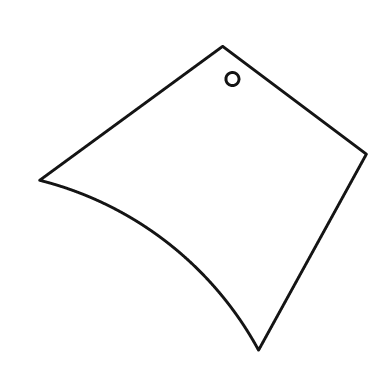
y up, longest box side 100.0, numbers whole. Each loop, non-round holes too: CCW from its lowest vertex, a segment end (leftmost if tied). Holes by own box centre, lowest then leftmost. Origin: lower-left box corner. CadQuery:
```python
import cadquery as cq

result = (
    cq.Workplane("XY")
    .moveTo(67.0, 0.0)
    .lineTo(100.0, 60.0)
    .lineTo(56.0, 93.0)
    .lineTo(0.0, 52.0)
    .threePointArc((39.0, 33.0), (67.0, 0.0))
    .close()
    .moveTo(59.0, 83.0)
    .circle(2.0)
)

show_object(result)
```